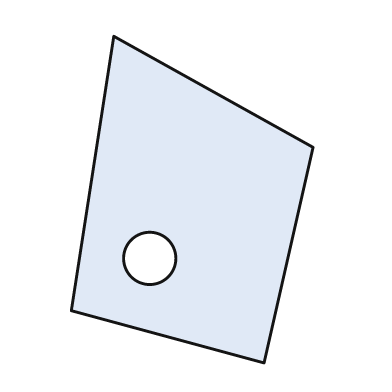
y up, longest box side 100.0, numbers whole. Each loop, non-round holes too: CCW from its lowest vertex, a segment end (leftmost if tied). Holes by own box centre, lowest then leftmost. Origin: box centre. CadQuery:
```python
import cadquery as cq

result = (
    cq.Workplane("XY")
    .moveTo(22.0, -50.0)
    .lineTo(37.0, 16.0)
    .lineTo(-24.0, 50.0)
    .lineTo(-37.0, -34.0)
    .close()
    .moveTo(-13.0, -18.0)
    .circle(8.0)
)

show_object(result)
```